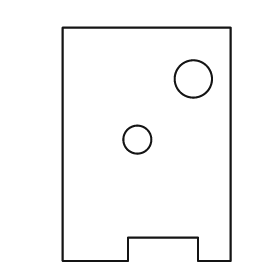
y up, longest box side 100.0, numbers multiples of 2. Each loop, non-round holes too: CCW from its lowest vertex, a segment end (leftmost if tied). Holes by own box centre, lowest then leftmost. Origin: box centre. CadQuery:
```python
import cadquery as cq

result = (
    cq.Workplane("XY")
    .moveTo(-36.0, -50.0)
    .lineTo(-8.0, -50.0)
    .lineTo(-8.0, -40.0)
    .lineTo(22.0, -40.0)
    .lineTo(22.0, -50.0)
    .lineTo(36.0, -50.0)
    .lineTo(36.0, 50.0)
    .lineTo(-36.0, 50.0)
    .close()
    .moveTo(-4.0, 2.0)
    .circle(6.0)
    .moveTo(20.0, 28.0)
    .circle(8.0)
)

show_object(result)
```